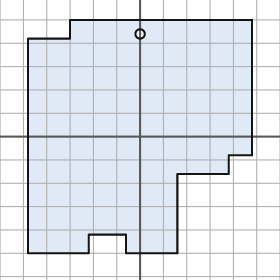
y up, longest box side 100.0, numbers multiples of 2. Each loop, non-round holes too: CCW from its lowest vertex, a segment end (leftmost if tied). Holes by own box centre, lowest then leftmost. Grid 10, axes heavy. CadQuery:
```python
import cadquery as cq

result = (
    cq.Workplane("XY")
    .moveTo(-48.0, -50.0)
    .lineTo(-22.0, -50.0)
    .lineTo(-22.0, -42.0)
    .lineTo(-6.0, -42.0)
    .lineTo(-6.0, -50.0)
    .lineTo(16.0, -50.0)
    .lineTo(16.0, -16.0)
    .lineTo(38.0, -16.0)
    .lineTo(38.0, -8.0)
    .lineTo(48.0, -8.0)
    .lineTo(48.0, 50.0)
    .lineTo(-30.0, 50.0)
    .lineTo(-30.0, 42.0)
    .lineTo(-48.0, 42.0)
    .close()
    .moveTo(0.0, 44.0)
    .circle(2.0)
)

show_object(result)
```